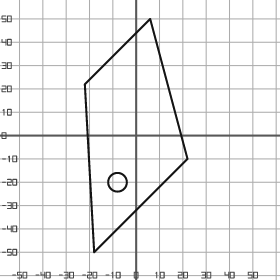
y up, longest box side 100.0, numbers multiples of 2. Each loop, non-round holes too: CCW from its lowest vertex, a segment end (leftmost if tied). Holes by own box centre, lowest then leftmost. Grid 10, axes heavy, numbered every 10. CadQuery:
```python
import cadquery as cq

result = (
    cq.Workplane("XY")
    .moveTo(-18.0, -50.0)
    .lineTo(22.0, -10.0)
    .lineTo(6.0, 50.0)
    .lineTo(-22.0, 22.0)
    .close()
    .moveTo(-8.0, -20.0)
    .circle(4.0)
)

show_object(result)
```